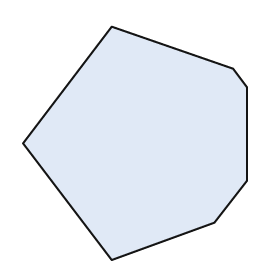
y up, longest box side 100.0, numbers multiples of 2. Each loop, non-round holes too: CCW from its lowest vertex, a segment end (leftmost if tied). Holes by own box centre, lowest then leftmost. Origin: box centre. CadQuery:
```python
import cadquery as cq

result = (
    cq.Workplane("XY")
    .moveTo(-10.0, -50.0)
    .lineTo(34.0, -34.0)
    .lineTo(48.0, -16.0)
    .lineTo(48.0, 24.0)
    .lineTo(42.0, 32.0)
    .lineTo(-10.0, 50.0)
    .lineTo(-48.0, 0.0)
    .close()
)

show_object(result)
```